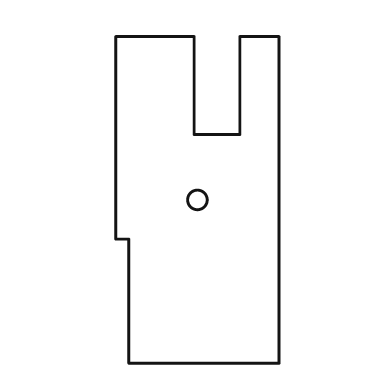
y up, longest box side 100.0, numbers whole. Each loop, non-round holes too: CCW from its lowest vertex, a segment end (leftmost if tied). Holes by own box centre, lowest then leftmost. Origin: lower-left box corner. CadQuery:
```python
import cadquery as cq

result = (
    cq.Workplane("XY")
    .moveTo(4.0, 0.0)
    .lineTo(50.0, 0.0)
    .lineTo(50.0, 100.0)
    .lineTo(38.0, 100.0)
    .lineTo(38.0, 70.0)
    .lineTo(24.0, 70.0)
    .lineTo(24.0, 100.0)
    .lineTo(0.0, 100.0)
    .lineTo(0.0, 38.0)
    .lineTo(4.0, 38.0)
    .close()
    .moveTo(25.0, 50.0)
    .circle(3.0)
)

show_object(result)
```